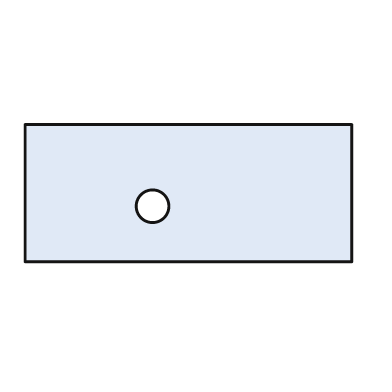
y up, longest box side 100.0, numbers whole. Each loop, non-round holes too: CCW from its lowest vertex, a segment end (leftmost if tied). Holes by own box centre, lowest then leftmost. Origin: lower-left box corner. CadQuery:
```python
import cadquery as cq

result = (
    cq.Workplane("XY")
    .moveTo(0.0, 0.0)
    .lineTo(100.0, 0.0)
    .lineTo(100.0, 42.0)
    .lineTo(0.0, 42.0)
    .close()
    .moveTo(39.0, 17.0)
    .circle(5.0)
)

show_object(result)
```